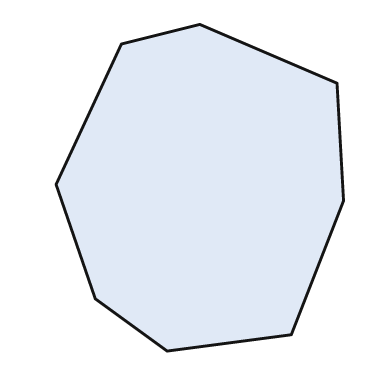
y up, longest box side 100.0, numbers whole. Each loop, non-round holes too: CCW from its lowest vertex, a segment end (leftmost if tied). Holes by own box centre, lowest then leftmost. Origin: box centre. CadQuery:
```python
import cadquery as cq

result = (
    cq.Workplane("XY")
    .moveTo(-10.0, -50.0)
    .lineTo(28.0, -45.0)
    .lineTo(44.0, -4.0)
    .lineTo(42.0, 32.0)
    .lineTo(0.0, 50.0)
    .lineTo(-24.0, 44.0)
    .lineTo(-44.0, 1.0)
    .lineTo(-32.0, -34.0)
    .close()
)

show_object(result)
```